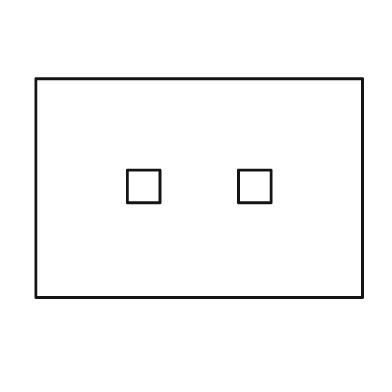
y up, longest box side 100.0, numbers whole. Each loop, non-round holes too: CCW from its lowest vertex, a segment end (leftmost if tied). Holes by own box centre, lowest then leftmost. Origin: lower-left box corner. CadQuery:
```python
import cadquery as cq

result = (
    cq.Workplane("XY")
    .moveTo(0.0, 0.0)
    .lineTo(100.0, 0.0)
    .lineTo(100.0, 67.0)
    .lineTo(0.0, 67.0)
    .close()
    .moveTo(28.0, 29.0)
    .lineTo(38.0, 29.0)
    .lineTo(38.0, 39.0)
    .lineTo(28.0, 39.0)
    .close()
    .moveTo(62.0, 29.0)
    .lineTo(72.0, 29.0)
    .lineTo(72.0, 39.0)
    .lineTo(62.0, 39.0)
    .close()
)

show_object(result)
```